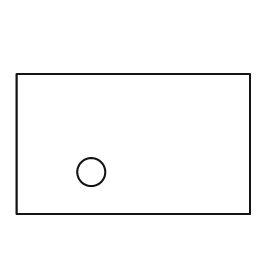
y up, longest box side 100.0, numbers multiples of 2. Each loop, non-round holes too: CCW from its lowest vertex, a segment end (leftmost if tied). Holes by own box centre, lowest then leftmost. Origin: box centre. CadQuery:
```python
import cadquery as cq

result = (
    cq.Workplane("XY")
    .moveTo(-50.0, -30.0)
    .lineTo(50.0, -30.0)
    .lineTo(50.0, 30.0)
    .lineTo(-50.0, 30.0)
    .close()
    .moveTo(-18.0, -12.0)
    .circle(6.0)
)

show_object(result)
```